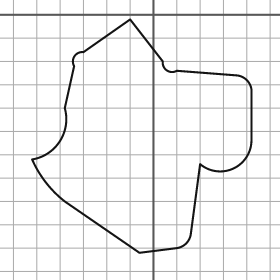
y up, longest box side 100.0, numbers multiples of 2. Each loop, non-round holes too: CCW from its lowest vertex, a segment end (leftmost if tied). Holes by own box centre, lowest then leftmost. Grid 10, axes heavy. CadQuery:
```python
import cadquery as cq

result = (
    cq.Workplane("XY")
    .moveTo(-6.0, -102.0)
    .lineTo(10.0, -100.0)
    .threePointArc((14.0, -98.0), (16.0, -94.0))
    .lineTo(20.0, -64.0)
    .threePointArc((34.0, -66.0), (42.0, -54.0))
    .lineTo(42.0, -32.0)
    .threePointArc((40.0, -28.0), (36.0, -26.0))
    .lineTo(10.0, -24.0)
    .threePointArc((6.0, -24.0), (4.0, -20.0))
    .lineTo(-10.0, -2.0)
    .lineTo(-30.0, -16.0)
    .threePointArc((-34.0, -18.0), (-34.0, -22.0))
    .lineTo(-38.0, -40.0)
    .threePointArc((-40.0, -54.0), (-52.0, -62.0))
    .threePointArc((-46.0, -72.0), (-38.0, -80.0))
    .close()
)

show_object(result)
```